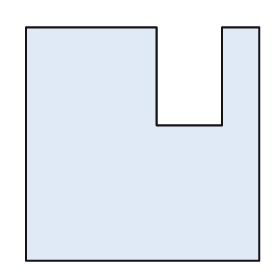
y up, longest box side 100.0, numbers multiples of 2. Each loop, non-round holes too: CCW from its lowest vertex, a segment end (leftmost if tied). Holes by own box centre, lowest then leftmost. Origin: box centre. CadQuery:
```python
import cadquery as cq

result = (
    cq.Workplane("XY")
    .moveTo(-50.0, -50.0)
    .lineTo(50.0, -50.0)
    .lineTo(50.0, 50.0)
    .lineTo(34.0, 50.0)
    .lineTo(34.0, 8.0)
    .lineTo(6.0, 8.0)
    .lineTo(6.0, 50.0)
    .lineTo(-50.0, 50.0)
    .close()
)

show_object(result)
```